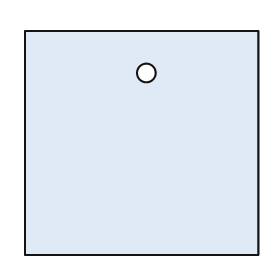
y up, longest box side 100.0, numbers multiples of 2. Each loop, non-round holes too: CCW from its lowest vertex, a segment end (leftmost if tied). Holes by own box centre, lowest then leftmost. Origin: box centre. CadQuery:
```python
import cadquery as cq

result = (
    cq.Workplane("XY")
    .moveTo(-50.0, -48.0)
    .lineTo(50.0, -48.0)
    .lineTo(50.0, 48.0)
    .lineTo(-50.0, 48.0)
    .close()
    .moveTo(2.0, 30.0)
    .circle(4.0)
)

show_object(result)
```